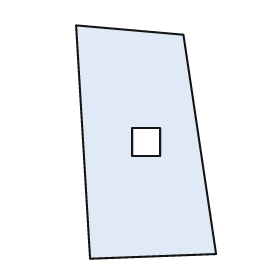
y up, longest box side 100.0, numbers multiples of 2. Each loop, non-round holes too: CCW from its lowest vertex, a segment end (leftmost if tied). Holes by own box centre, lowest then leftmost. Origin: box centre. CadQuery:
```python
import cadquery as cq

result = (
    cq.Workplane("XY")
    .moveTo(-24.0, -50.0)
    .lineTo(30.0, -48.0)
    .lineTo(16.0, 46.0)
    .lineTo(-30.0, 50.0)
    .close()
    .moveTo(-6.0, -6.0)
    .lineTo(6.0, -6.0)
    .lineTo(6.0, 6.0)
    .lineTo(-6.0, 6.0)
    .close()
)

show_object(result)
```